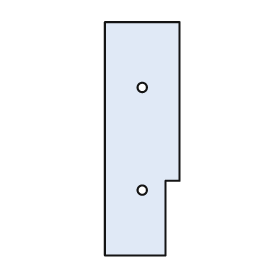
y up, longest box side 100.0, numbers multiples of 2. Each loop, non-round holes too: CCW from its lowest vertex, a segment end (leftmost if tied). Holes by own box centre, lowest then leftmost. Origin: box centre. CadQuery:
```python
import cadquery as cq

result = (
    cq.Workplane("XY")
    .moveTo(-16.0, -50.0)
    .lineTo(10.0, -50.0)
    .lineTo(10.0, -18.0)
    .lineTo(16.0, -18.0)
    .lineTo(16.0, 50.0)
    .lineTo(-16.0, 50.0)
    .close()
    .moveTo(0.0, -22.0)
    .circle(2.0)
    .moveTo(0.0, 22.0)
    .circle(2.0)
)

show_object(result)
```